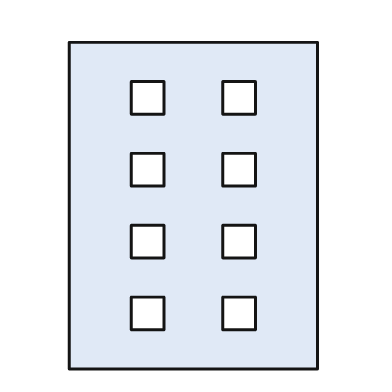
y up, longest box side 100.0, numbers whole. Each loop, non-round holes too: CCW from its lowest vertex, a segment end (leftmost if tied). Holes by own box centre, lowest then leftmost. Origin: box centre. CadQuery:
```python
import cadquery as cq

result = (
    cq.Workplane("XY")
    .moveTo(-38.0, -50.0)
    .lineTo(38.0, -50.0)
    .lineTo(38.0, 50.0)
    .lineTo(-38.0, 50.0)
    .close()
    .moveTo(-19.0, -38.0)
    .lineTo(-9.0, -38.0)
    .lineTo(-9.0, -28.0)
    .lineTo(-19.0, -28.0)
    .close()
    .moveTo(9.0, -38.0)
    .lineTo(19.0, -38.0)
    .lineTo(19.0, -28.0)
    .lineTo(9.0, -28.0)
    .close()
    .moveTo(-19.0, -16.0)
    .lineTo(-9.0, -16.0)
    .lineTo(-9.0, -6.0)
    .lineTo(-19.0, -6.0)
    .close()
    .moveTo(9.0, -16.0)
    .lineTo(19.0, -16.0)
    .lineTo(19.0, -6.0)
    .lineTo(9.0, -6.0)
    .close()
    .moveTo(-19.0, 6.0)
    .lineTo(-9.0, 6.0)
    .lineTo(-9.0, 16.0)
    .lineTo(-19.0, 16.0)
    .close()
    .moveTo(9.0, 6.0)
    .lineTo(19.0, 6.0)
    .lineTo(19.0, 16.0)
    .lineTo(9.0, 16.0)
    .close()
    .moveTo(-19.0, 28.0)
    .lineTo(-9.0, 28.0)
    .lineTo(-9.0, 38.0)
    .lineTo(-19.0, 38.0)
    .close()
    .moveTo(9.0, 28.0)
    .lineTo(19.0, 28.0)
    .lineTo(19.0, 38.0)
    .lineTo(9.0, 38.0)
    .close()
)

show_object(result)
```